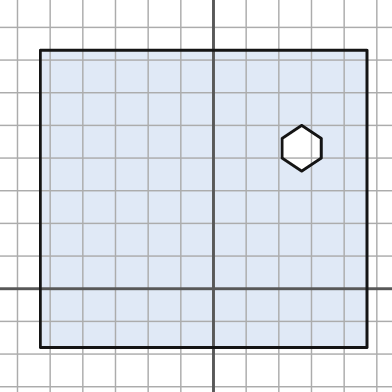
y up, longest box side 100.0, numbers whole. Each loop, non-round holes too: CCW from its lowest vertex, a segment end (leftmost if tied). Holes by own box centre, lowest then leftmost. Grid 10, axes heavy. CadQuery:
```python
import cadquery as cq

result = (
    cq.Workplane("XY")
    .moveTo(-53.0, -18.0)
    .lineTo(47.0, -18.0)
    .lineTo(47.0, 73.0)
    .lineTo(-53.0, 73.0)
    .close()
    .moveTo(27.0, 36.0)
    .lineTo(33.0, 40.0)
    .lineTo(33.0, 46.0)
    .lineTo(27.0, 50.0)
    .lineTo(21.0, 46.0)
    .lineTo(21.0, 40.0)
    .close()
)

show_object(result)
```